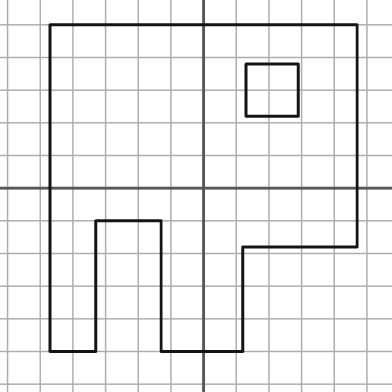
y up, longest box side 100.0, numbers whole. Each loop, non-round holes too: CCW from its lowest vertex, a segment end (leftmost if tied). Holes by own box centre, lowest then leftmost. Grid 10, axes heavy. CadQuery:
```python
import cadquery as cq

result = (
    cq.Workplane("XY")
    .moveTo(-47.0, -50.0)
    .lineTo(-33.0, -50.0)
    .lineTo(-33.0, -10.0)
    .lineTo(-13.0, -10.0)
    .lineTo(-13.0, -50.0)
    .lineTo(12.0, -50.0)
    .lineTo(12.0, -18.0)
    .lineTo(47.0, -18.0)
    .lineTo(47.0, 50.0)
    .lineTo(-47.0, 50.0)
    .close()
    .moveTo(13.0, 22.0)
    .lineTo(29.0, 22.0)
    .lineTo(29.0, 38.0)
    .lineTo(13.0, 38.0)
    .close()
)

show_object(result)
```